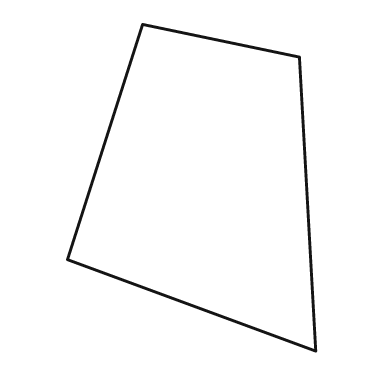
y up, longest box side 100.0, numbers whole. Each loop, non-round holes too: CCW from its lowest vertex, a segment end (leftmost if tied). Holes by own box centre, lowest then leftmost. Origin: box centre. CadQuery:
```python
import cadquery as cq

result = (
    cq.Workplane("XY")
    .moveTo(38.0, -50.0)
    .lineTo(33.0, 40.0)
    .lineTo(-15.0, 50.0)
    .lineTo(-38.0, -22.0)
    .close()
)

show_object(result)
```